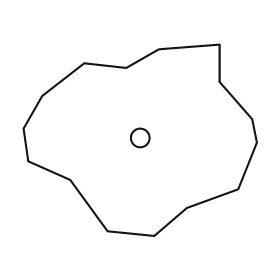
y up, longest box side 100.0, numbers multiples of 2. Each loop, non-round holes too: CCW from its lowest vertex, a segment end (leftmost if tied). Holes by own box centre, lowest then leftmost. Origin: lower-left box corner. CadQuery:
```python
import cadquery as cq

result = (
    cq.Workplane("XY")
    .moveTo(56.0, 0.0)
    .lineTo(70.0, 12.0)
    .lineTo(92.0, 20.0)
    .lineTo(100.0, 40.0)
    .lineTo(98.0, 50.0)
    .lineTo(84.0, 66.0)
    .lineTo(84.0, 82.0)
    .lineTo(58.0, 80.0)
    .lineTo(44.0, 72.0)
    .lineTo(26.0, 74.0)
    .lineTo(8.0, 60.0)
    .lineTo(0.0, 46.0)
    .lineTo(2.0, 32.0)
    .lineTo(20.0, 24.0)
    .lineTo(36.0, 2.0)
    .close()
    .moveTo(50.0, 42.0)
    .circle(4.0)
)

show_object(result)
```